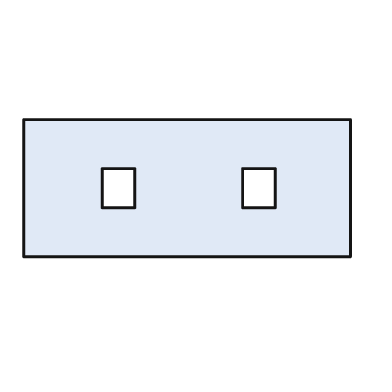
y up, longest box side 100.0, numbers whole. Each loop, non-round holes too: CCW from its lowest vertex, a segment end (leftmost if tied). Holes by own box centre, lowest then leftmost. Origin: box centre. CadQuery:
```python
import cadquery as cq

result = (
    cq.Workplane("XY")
    .moveTo(-50.0, -21.0)
    .lineTo(50.0, -21.0)
    .lineTo(50.0, 21.0)
    .lineTo(-50.0, 21.0)
    .close()
    .moveTo(-26.0, -6.0)
    .lineTo(-16.0, -6.0)
    .lineTo(-16.0, 6.0)
    .lineTo(-26.0, 6.0)
    .close()
    .moveTo(17.0, -6.0)
    .lineTo(27.0, -6.0)
    .lineTo(27.0, 6.0)
    .lineTo(17.0, 6.0)
    .close()
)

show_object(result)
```